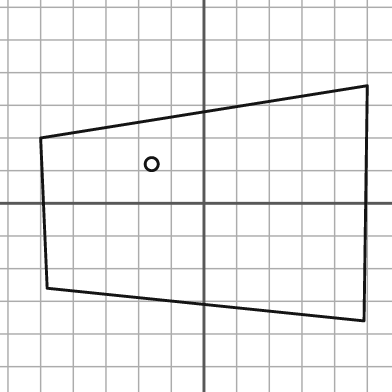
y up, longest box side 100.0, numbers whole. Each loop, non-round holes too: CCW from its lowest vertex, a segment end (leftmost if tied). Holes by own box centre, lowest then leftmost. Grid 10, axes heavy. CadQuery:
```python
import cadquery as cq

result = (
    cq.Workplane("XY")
    .moveTo(49.0, -36.0)
    .lineTo(50.0, 36.0)
    .lineTo(-50.0, 20.0)
    .lineTo(-48.0, -26.0)
    .close()
    .moveTo(-16.0, 12.0)
    .circle(2.0)
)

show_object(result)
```